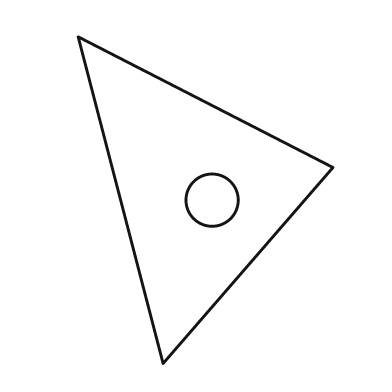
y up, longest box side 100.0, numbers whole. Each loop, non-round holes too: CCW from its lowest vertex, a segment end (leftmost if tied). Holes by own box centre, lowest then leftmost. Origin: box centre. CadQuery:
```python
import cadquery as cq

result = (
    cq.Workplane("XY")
    .moveTo(-13.0, -50.0)
    .lineTo(39.0, 10.0)
    .lineTo(-39.0, 50.0)
    .close()
    .moveTo(2.0, 0.0)
    .circle(8.0)
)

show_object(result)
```